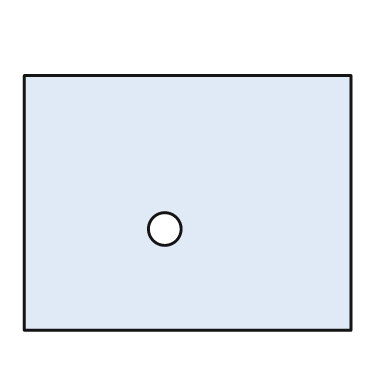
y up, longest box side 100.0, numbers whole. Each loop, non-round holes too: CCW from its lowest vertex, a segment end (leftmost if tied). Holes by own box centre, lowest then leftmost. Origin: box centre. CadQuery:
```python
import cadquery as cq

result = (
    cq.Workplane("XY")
    .moveTo(-50.0, -39.0)
    .lineTo(50.0, -39.0)
    .lineTo(50.0, 39.0)
    .lineTo(-50.0, 39.0)
    .close()
    .moveTo(-7.0, -8.0)
    .circle(5.0)
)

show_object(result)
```